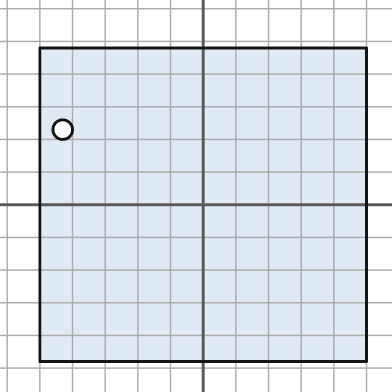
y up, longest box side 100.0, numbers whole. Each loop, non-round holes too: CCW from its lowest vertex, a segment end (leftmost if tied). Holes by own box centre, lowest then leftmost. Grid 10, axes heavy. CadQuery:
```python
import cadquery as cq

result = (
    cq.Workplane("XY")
    .moveTo(-50.0, -48.0)
    .lineTo(50.0, -48.0)
    .lineTo(50.0, 48.0)
    .lineTo(-50.0, 48.0)
    .close()
    .moveTo(-43.0, 23.0)
    .circle(3.0)
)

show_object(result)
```